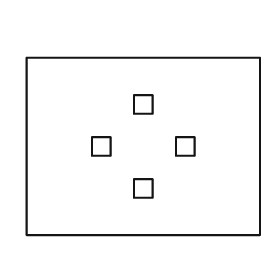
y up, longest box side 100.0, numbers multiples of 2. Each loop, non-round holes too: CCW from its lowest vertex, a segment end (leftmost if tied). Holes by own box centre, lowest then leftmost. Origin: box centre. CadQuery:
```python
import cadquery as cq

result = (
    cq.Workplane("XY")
    .moveTo(-50.0, -38.0)
    .lineTo(50.0, -38.0)
    .lineTo(50.0, 38.0)
    .lineTo(-50.0, 38.0)
    .close()
    .moveTo(-4.0, -22.0)
    .lineTo(4.0, -22.0)
    .lineTo(4.0, -14.0)
    .lineTo(-4.0, -14.0)
    .close()
    .moveTo(-22.0, -4.0)
    .lineTo(-14.0, -4.0)
    .lineTo(-14.0, 4.0)
    .lineTo(-22.0, 4.0)
    .close()
    .moveTo(14.0, -4.0)
    .lineTo(22.0, -4.0)
    .lineTo(22.0, 4.0)
    .lineTo(14.0, 4.0)
    .close()
    .moveTo(-4.0, 14.0)
    .lineTo(4.0, 14.0)
    .lineTo(4.0, 22.0)
    .lineTo(-4.0, 22.0)
    .close()
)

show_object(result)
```